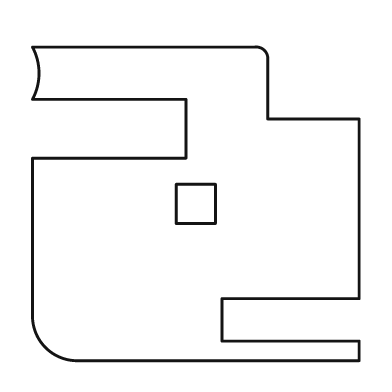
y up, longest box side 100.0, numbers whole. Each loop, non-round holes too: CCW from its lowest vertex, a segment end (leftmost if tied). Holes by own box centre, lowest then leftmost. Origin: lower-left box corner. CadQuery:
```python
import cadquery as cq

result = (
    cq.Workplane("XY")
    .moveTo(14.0, 0.0)
    .lineTo(100.0, 0.0)
    .lineTo(100.0, 6.0)
    .lineTo(58.0, 6.0)
    .lineTo(58.0, 19.0)
    .lineTo(100.0, 19.0)
    .lineTo(100.0, 74.0)
    .lineTo(72.0, 74.0)
    .lineTo(72.0, 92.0)
    .threePointArc((71.0, 95.0), (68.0, 96.0))
    .lineTo(0.0, 96.0)
    .threePointArc((2.0, 88.0), (0.0, 80.0))
    .lineTo(47.0, 80.0)
    .lineTo(47.0, 62.0)
    .lineTo(0.0, 62.0)
    .lineTo(0.0, 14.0)
    .threePointArc((4.0, 4.0), (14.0, 0.0))
    .close()
    .moveTo(44.0, 42.0)
    .lineTo(56.0, 42.0)
    .lineTo(56.0, 54.0)
    .lineTo(44.0, 54.0)
    .close()
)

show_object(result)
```